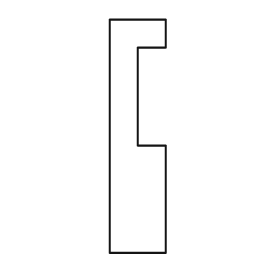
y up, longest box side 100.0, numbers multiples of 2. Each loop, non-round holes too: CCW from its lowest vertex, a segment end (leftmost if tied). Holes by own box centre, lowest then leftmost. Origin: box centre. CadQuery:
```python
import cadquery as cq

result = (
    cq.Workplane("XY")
    .moveTo(-12.0, -50.0)
    .lineTo(12.0, -50.0)
    .lineTo(12.0, -4.0)
    .lineTo(0.0, -4.0)
    .lineTo(0.0, 38.0)
    .lineTo(12.0, 38.0)
    .lineTo(12.0, 50.0)
    .lineTo(-12.0, 50.0)
    .close()
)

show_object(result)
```